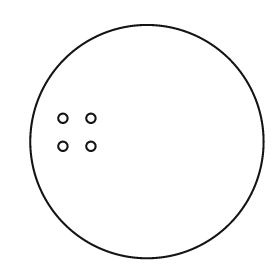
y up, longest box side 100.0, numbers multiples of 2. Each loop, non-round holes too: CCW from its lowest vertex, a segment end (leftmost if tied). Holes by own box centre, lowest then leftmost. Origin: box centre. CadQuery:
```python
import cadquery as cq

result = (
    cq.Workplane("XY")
    .moveTo(0.0, 0.0)
    .circle(50.0)
    .moveTo(-36.0, -2.0)
    .circle(2.0)
    .moveTo(-24.0, -2.0)
    .circle(2.0)
    .moveTo(-36.0, 10.0)
    .circle(2.0)
    .moveTo(-24.0, 10.0)
    .circle(2.0)
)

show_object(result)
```